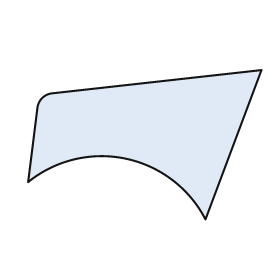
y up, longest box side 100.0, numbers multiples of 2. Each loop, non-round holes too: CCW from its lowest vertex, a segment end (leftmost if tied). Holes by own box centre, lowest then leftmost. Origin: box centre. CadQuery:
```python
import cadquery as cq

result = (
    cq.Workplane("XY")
    .moveTo(26.0, -32.0)
    .lineTo(50.0, 32.0)
    .lineTo(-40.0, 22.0)
    .threePointArc((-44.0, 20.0), (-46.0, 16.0))
    .lineTo(-50.0, -16.0)
    .threePointArc((-8.0, -6.0), (26.0, -32.0))
    .close()
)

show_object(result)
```